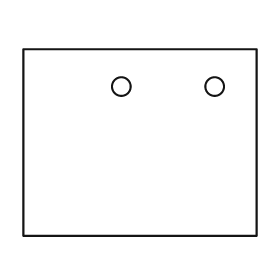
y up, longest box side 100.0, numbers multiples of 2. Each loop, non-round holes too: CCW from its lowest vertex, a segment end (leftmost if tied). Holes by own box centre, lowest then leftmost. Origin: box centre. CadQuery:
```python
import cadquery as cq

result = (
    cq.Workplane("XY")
    .moveTo(-50.0, -40.0)
    .lineTo(50.0, -40.0)
    .lineTo(50.0, 40.0)
    .lineTo(-50.0, 40.0)
    .close()
    .moveTo(-8.0, 24.0)
    .circle(4.0)
    .moveTo(32.0, 24.0)
    .circle(4.0)
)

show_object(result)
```